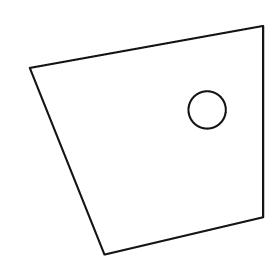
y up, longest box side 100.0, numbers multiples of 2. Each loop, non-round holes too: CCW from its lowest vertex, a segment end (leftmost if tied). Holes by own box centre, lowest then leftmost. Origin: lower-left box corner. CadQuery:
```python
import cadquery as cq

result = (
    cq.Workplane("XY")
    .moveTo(32.0, 0.0)
    .lineTo(100.0, 16.0)
    .lineTo(100.0, 98.0)
    .lineTo(0.0, 80.0)
    .close()
    .moveTo(76.0, 62.0)
    .circle(8.0)
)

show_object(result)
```